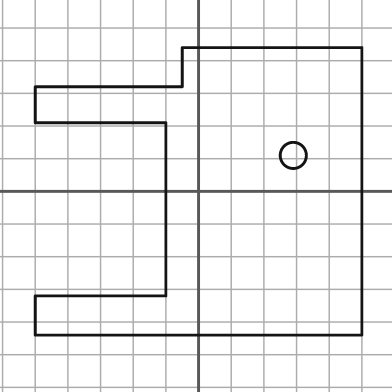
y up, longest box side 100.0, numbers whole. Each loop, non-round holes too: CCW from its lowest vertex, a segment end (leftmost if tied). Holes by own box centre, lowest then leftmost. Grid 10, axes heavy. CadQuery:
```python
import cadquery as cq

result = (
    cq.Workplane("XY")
    .moveTo(-50.0, -44.0)
    .lineTo(50.0, -44.0)
    .lineTo(50.0, 44.0)
    .lineTo(-5.0, 44.0)
    .lineTo(-5.0, 32.0)
    .lineTo(-50.0, 32.0)
    .lineTo(-50.0, 21.0)
    .lineTo(-10.0, 21.0)
    .lineTo(-10.0, -32.0)
    .lineTo(-50.0, -32.0)
    .close()
    .moveTo(29.0, 11.0)
    .circle(4.0)
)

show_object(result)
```